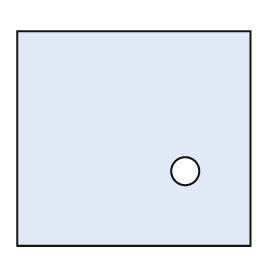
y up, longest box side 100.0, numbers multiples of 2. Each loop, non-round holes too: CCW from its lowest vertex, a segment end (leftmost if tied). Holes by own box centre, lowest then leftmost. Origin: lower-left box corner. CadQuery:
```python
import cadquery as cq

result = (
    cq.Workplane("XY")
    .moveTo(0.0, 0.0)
    .lineTo(100.0, 0.0)
    .lineTo(100.0, 92.0)
    .lineTo(0.0, 92.0)
    .close()
    .moveTo(72.0, 32.0)
    .circle(6.0)
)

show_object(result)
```